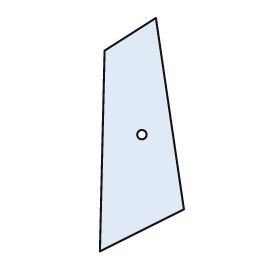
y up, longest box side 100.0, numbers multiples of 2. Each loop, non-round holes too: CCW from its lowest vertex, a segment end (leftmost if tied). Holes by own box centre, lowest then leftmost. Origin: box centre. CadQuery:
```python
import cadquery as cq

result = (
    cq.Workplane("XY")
    .moveTo(-18.0, -50.0)
    .lineTo(18.0, -32.0)
    .lineTo(6.0, 50.0)
    .lineTo(-16.0, 36.0)
    .close()
    .moveTo(0.0, 0.0)
    .circle(2.0)
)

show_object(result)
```